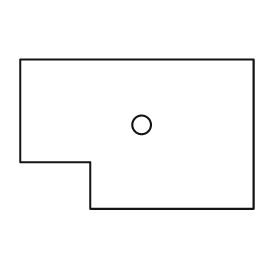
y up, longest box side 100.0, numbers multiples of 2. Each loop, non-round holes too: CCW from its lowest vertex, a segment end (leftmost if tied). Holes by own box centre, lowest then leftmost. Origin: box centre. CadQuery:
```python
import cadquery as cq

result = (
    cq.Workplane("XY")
    .moveTo(-20.0, -32.0)
    .lineTo(50.0, -32.0)
    .lineTo(50.0, 32.0)
    .lineTo(-50.0, 32.0)
    .lineTo(-50.0, -12.0)
    .lineTo(-20.0, -12.0)
    .close()
    .moveTo(2.0, 4.0)
    .circle(4.0)
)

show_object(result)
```